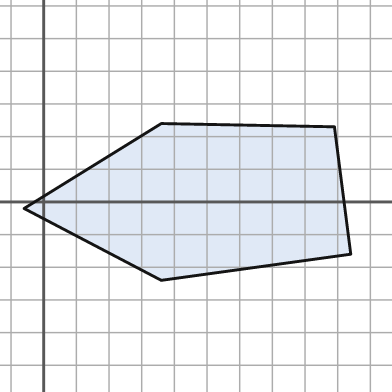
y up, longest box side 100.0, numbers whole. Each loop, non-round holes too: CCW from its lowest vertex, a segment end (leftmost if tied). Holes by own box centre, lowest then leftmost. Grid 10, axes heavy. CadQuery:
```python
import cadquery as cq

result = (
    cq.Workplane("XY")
    .moveTo(36.0, -24.0)
    .lineTo(94.0, -16.0)
    .lineTo(89.0, 23.0)
    .lineTo(36.0, 24.0)
    .lineTo(-6.0, -2.0)
    .close()
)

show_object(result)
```